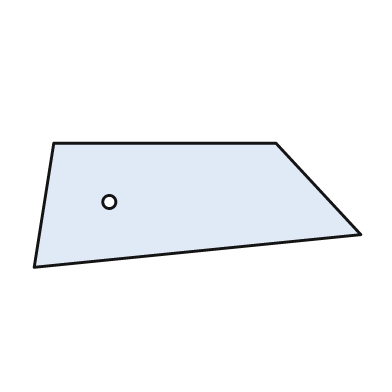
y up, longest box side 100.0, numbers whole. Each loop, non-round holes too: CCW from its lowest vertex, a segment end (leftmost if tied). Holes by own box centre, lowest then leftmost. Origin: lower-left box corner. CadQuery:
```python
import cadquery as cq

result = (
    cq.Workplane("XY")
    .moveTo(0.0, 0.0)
    .lineTo(100.0, 10.0)
    .lineTo(74.0, 38.0)
    .lineTo(6.0, 38.0)
    .close()
    .moveTo(23.0, 20.0)
    .circle(2.0)
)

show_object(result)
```